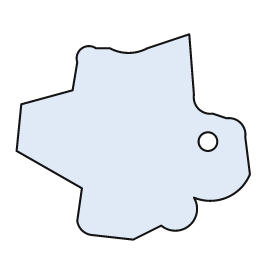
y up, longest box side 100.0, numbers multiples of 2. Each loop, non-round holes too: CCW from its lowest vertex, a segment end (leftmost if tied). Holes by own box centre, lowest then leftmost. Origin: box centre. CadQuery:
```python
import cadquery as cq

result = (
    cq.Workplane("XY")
    .moveTo(0.0, -44.0)
    .lineTo(12.0, -38.0)
    .threePointArc((24.0, -38.0), (26.0, -26.0))
    .threePointArc((40.0, -26.0), (50.0, -16.0))
    .lineTo(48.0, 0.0)
    .threePointArc((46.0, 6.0), (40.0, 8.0))
    .lineTo(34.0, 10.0)
    .threePointArc((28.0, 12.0), (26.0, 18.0))
    .lineTo(24.0, 44.0)
    .lineTo(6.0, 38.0)
    .threePointArc((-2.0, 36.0), (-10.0, 38.0))
    .lineTo(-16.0, 38.0)
    .threePointArc((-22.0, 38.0), (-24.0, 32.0))
    .lineTo(-26.0, 20.0)
    .lineTo(-48.0, 14.0)
    .lineTo(-50.0, -6.0)
    .lineTo(-22.0, -22.0)
    .lineTo(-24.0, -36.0)
    .threePointArc((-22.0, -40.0), (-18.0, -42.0))
    .close()
    .moveTo(32.0, -2.0)
    .circle(4.0)
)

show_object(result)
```